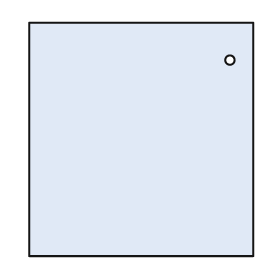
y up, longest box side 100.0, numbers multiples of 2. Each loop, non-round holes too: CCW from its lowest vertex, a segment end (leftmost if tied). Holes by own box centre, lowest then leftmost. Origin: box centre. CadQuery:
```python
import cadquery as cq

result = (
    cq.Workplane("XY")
    .moveTo(-48.0, -50.0)
    .lineTo(48.0, -50.0)
    .lineTo(48.0, 50.0)
    .lineTo(-48.0, 50.0)
    .close()
    .moveTo(38.0, 34.0)
    .circle(2.0)
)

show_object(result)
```